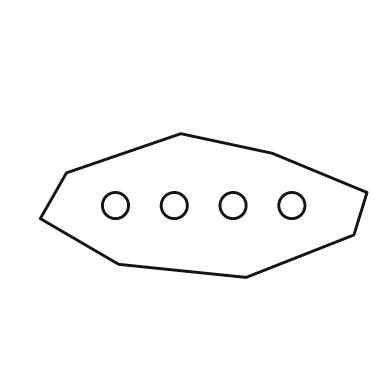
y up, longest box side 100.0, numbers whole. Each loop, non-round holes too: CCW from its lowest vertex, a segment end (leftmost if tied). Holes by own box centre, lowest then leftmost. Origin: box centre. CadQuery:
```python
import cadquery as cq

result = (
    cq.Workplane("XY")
    .moveTo(13.0, -22.0)
    .lineTo(46.0, -9.0)
    .lineTo(50.0, 4.0)
    .lineTo(21.0, 16.0)
    .lineTo(-7.0, 22.0)
    .lineTo(-42.0, 10.0)
    .lineTo(-50.0, -4.0)
    .lineTo(-26.0, -18.0)
    .close()
    .moveTo(-27.0, 0.0)
    .circle(4.0)
    .moveTo(-9.0, 0.0)
    .circle(4.0)
    .moveTo(9.0, 0.0)
    .circle(4.0)
    .moveTo(27.0, 0.0)
    .circle(4.0)
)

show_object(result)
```